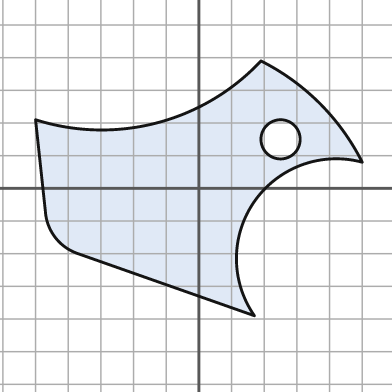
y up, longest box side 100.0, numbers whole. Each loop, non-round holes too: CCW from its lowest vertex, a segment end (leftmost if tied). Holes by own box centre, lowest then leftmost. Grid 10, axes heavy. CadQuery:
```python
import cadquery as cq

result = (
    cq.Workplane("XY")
    .moveTo(17.0, -39.0)
    .threePointArc((17.0, -4.0), (50.0, 8.0))
    .threePointArc((37.0, 26.0), (19.0, 39.0))
    .threePointArc((-13.0, 20.0), (-50.0, 21.0))
    .lineTo(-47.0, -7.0)
    .threePointArc((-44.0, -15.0), (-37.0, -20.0))
    .close()
    .moveTo(25.0, 15.0)
    .circle(6.0)
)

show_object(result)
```